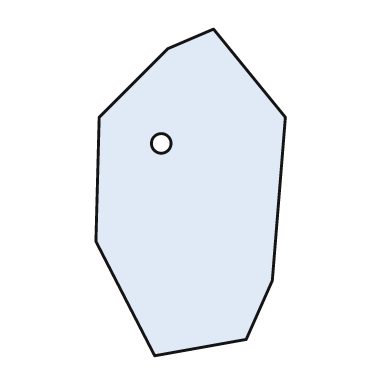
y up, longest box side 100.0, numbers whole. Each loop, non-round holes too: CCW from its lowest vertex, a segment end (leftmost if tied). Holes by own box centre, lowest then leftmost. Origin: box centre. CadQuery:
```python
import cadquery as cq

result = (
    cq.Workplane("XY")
    .moveTo(-11.0, -50.0)
    .lineTo(17.0, -45.0)
    .lineTo(25.0, -27.0)
    .lineTo(29.0, 23.0)
    .lineTo(7.0, 50.0)
    .lineTo(-7.0, 44.0)
    .lineTo(-28.0, 23.0)
    .lineTo(-29.0, -15.0)
    .close()
    .moveTo(-9.0, 15.0)
    .circle(3.0)
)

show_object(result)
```